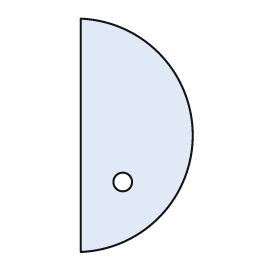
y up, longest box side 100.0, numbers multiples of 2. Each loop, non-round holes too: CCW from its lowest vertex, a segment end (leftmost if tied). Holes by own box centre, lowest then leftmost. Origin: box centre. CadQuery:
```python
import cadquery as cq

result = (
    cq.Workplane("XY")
    .moveTo(-24.0, -50.0)
    .threePointArc((24.0, 0.0), (-24.0, 50.0))
    .close()
    .moveTo(-6.0, -20.0)
    .circle(4.0)
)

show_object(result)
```